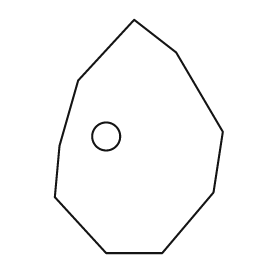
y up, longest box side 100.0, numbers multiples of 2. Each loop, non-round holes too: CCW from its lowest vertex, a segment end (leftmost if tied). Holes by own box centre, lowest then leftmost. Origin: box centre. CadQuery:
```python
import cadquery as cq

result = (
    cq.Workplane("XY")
    .moveTo(-14.0, -50.0)
    .lineTo(10.0, -50.0)
    .lineTo(32.0, -24.0)
    .lineTo(36.0, 2.0)
    .lineTo(16.0, 36.0)
    .lineTo(-2.0, 50.0)
    .lineTo(-26.0, 24.0)
    .lineTo(-34.0, -4.0)
    .lineTo(-36.0, -26.0)
    .close()
    .moveTo(-14.0, 0.0)
    .circle(6.0)
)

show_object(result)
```